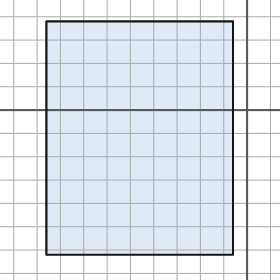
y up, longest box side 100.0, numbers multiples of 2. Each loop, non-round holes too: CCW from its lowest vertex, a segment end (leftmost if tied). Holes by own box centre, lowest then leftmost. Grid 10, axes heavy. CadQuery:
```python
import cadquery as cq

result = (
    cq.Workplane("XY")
    .moveTo(-86.0, -62.0)
    .lineTo(-6.0, -62.0)
    .lineTo(-6.0, 38.0)
    .lineTo(-86.0, 38.0)
    .close()
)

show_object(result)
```